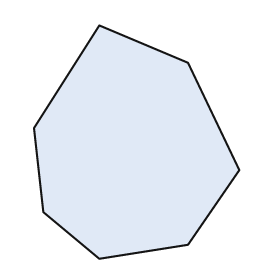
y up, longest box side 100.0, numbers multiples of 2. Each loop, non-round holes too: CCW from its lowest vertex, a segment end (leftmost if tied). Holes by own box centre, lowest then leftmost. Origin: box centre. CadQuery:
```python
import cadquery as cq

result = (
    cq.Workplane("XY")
    .moveTo(-16.0, -50.0)
    .lineTo(22.0, -44.0)
    .lineTo(44.0, -12.0)
    .lineTo(22.0, 34.0)
    .lineTo(-16.0, 50.0)
    .lineTo(-44.0, 6.0)
    .lineTo(-40.0, -30.0)
    .close()
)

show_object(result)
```